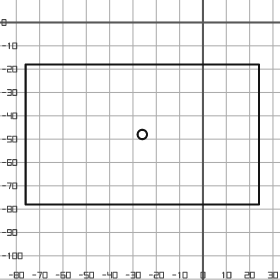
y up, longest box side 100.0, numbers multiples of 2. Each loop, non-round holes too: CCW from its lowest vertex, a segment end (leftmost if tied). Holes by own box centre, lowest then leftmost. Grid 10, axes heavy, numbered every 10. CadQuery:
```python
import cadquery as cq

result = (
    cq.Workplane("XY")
    .moveTo(-76.0, -78.0)
    .lineTo(24.0, -78.0)
    .lineTo(24.0, -18.0)
    .lineTo(-76.0, -18.0)
    .close()
    .moveTo(-26.0, -48.0)
    .circle(2.0)
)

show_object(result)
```